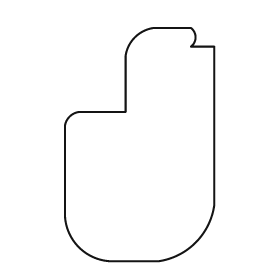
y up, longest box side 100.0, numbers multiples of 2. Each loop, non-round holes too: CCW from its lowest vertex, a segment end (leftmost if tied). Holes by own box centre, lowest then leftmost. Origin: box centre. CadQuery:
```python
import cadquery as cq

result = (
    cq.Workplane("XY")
    .moveTo(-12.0, -50.0)
    .lineTo(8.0, -50.0)
    .threePointArc((24.0, -42.0), (32.0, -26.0))
    .lineTo(32.0, 42.0)
    .lineTo(22.0, 42.0)
    .threePointArc((24.0, 46.0), (22.0, 50.0))
    .lineTo(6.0, 50.0)
    .threePointArc((-2.0, 46.0), (-6.0, 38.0))
    .lineTo(-6.0, 14.0)
    .lineTo(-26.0, 14.0)
    .threePointArc((-30.0, 12.0), (-32.0, 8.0))
    .lineTo(-32.0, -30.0)
    .threePointArc((-26.0, -44.0), (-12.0, -50.0))
    .close()
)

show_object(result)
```